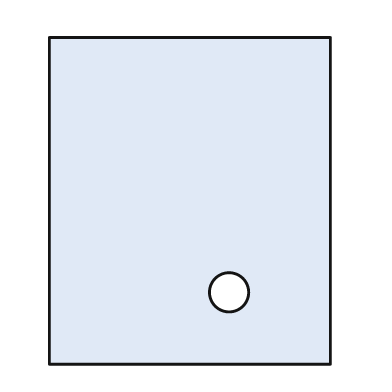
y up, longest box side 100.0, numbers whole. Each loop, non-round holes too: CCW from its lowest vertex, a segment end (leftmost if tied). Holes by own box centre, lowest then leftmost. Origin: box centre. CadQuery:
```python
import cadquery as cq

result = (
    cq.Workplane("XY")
    .moveTo(-43.0, -50.0)
    .lineTo(43.0, -50.0)
    .lineTo(43.0, 50.0)
    .lineTo(-43.0, 50.0)
    .close()
    .moveTo(12.0, -28.0)
    .circle(6.0)
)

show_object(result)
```